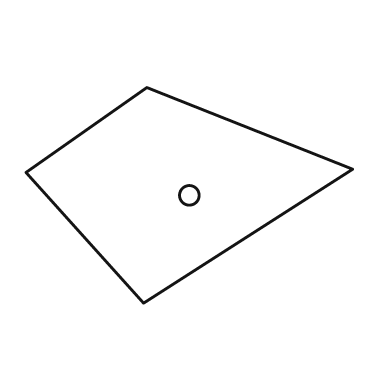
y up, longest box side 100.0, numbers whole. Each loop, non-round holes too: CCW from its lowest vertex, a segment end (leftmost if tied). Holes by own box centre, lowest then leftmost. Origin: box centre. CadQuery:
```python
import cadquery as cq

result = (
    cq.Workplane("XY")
    .moveTo(-14.0, -33.0)
    .lineTo(50.0, 8.0)
    .lineTo(-13.0, 33.0)
    .lineTo(-50.0, 7.0)
    .close()
    .moveTo(0.0, 0.0)
    .circle(3.0)
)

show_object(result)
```